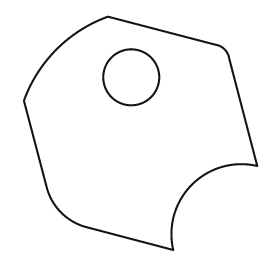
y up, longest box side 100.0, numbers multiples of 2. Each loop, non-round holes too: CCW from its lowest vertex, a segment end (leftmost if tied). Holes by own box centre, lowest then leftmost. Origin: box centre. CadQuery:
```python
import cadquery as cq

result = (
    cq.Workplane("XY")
    .moveTo(14.0, -50.0)
    .threePointArc((22.0, -22.0), (50.0, -14.0))
    .lineTo(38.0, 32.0)
    .threePointArc((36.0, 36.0), (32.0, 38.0))
    .lineTo(-14.0, 50.0)
    .threePointArc((-36.0, 36.0), (-50.0, 14.0))
    .lineTo(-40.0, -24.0)
    .threePointArc((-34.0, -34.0), (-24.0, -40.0))
    .close()
    .moveTo(-4.0, 24.0)
    .circle(12.0)
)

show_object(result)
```